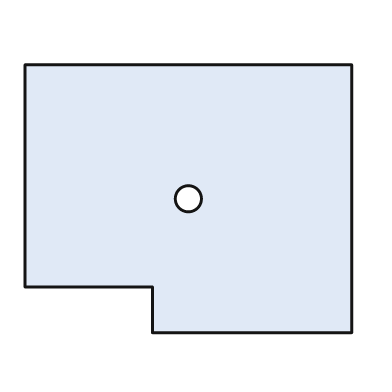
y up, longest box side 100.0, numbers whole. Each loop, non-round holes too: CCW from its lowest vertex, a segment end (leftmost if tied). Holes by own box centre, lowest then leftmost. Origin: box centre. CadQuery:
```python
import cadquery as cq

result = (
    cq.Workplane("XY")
    .moveTo(-11.0, -41.0)
    .lineTo(50.0, -41.0)
    .lineTo(50.0, 41.0)
    .lineTo(-50.0, 41.0)
    .lineTo(-50.0, -27.0)
    .lineTo(-11.0, -27.0)
    .close()
    .moveTo(0.0, 0.0)
    .circle(4.0)
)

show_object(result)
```